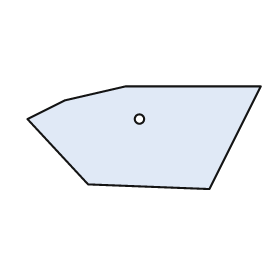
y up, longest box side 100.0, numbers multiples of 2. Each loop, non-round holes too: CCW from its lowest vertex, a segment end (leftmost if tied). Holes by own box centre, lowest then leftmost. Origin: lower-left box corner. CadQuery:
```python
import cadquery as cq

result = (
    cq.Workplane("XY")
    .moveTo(78.0, 0.0)
    .lineTo(100.0, 44.0)
    .lineTo(42.0, 44.0)
    .lineTo(16.0, 38.0)
    .lineTo(0.0, 30.0)
    .lineTo(26.0, 2.0)
    .close()
    .moveTo(48.0, 30.0)
    .circle(2.0)
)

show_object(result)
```